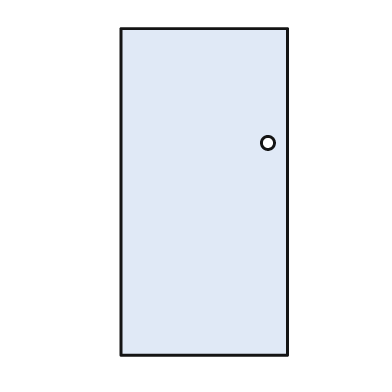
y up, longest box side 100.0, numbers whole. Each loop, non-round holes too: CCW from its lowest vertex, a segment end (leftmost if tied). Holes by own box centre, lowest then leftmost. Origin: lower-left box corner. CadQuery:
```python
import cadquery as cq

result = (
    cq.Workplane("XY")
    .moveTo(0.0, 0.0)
    .lineTo(51.0, 0.0)
    .lineTo(51.0, 100.0)
    .lineTo(0.0, 100.0)
    .close()
    .moveTo(45.0, 65.0)
    .circle(2.0)
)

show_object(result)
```